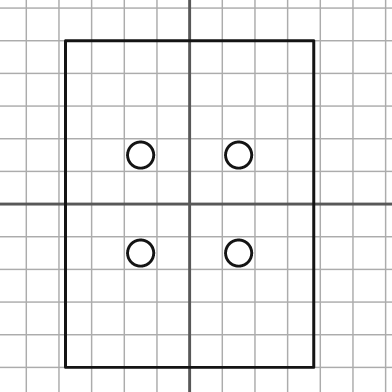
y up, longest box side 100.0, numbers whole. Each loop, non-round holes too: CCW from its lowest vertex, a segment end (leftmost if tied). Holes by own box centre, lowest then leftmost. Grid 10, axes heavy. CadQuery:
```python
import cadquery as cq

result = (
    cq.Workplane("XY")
    .moveTo(-38.0, -50.0)
    .lineTo(38.0, -50.0)
    .lineTo(38.0, 50.0)
    .lineTo(-38.0, 50.0)
    .close()
    .moveTo(-15.0, -15.0)
    .circle(4.0)
    .moveTo(15.0, -15.0)
    .circle(4.0)
    .moveTo(-15.0, 15.0)
    .circle(4.0)
    .moveTo(15.0, 15.0)
    .circle(4.0)
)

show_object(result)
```